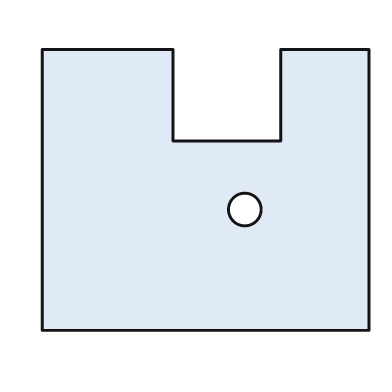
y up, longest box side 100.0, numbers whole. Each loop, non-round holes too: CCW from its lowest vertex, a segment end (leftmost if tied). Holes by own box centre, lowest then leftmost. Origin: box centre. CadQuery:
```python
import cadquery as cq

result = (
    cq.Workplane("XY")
    .moveTo(-50.0, -43.0)
    .lineTo(50.0, -43.0)
    .lineTo(50.0, 43.0)
    .lineTo(23.0, 43.0)
    .lineTo(23.0, 15.0)
    .lineTo(-10.0, 15.0)
    .lineTo(-10.0, 43.0)
    .lineTo(-50.0, 43.0)
    .close()
    .moveTo(12.0, -6.0)
    .circle(5.0)
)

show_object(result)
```